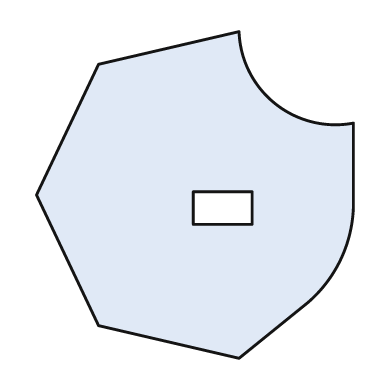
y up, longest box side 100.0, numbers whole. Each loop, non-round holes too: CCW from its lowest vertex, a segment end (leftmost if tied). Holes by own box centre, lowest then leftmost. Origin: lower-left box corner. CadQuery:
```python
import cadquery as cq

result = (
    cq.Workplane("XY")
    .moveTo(62.0, 0.0)
    .lineTo(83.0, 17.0)
    .threePointArc((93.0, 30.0), (97.0, 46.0))
    .lineTo(97.0, 72.0)
    .threePointArc((73.0, 78.0), (62.0, 100.0))
    .lineTo(19.0, 90.0)
    .lineTo(0.0, 50.0)
    .lineTo(19.0, 10.0)
    .close()
    .moveTo(48.0, 41.0)
    .lineTo(66.0, 41.0)
    .lineTo(66.0, 51.0)
    .lineTo(48.0, 51.0)
    .close()
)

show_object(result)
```